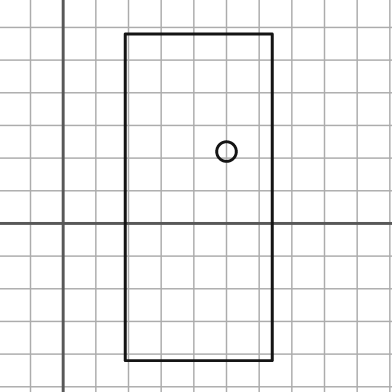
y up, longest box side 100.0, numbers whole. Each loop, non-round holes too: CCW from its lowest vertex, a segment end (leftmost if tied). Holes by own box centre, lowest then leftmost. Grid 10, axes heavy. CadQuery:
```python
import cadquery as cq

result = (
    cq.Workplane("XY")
    .moveTo(19.0, -42.0)
    .lineTo(64.0, -42.0)
    .lineTo(64.0, 58.0)
    .lineTo(19.0, 58.0)
    .close()
    .moveTo(50.0, 22.0)
    .circle(3.0)
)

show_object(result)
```